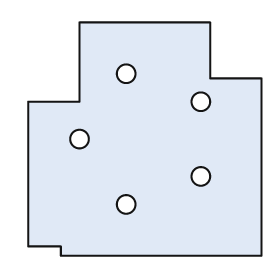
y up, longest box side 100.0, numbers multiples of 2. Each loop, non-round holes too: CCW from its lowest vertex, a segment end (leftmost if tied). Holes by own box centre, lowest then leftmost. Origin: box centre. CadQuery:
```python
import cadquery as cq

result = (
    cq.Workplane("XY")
    .moveTo(-36.0, -50.0)
    .lineTo(50.0, -50.0)
    .lineTo(50.0, 26.0)
    .lineTo(28.0, 26.0)
    .lineTo(28.0, 50.0)
    .lineTo(-28.0, 50.0)
    .lineTo(-28.0, 16.0)
    .lineTo(-50.0, 16.0)
    .lineTo(-50.0, -46.0)
    .lineTo(-36.0, -46.0)
    .close()
    .moveTo(-8.0, -28.0)
    .circle(4.0)
    .moveTo(24.0, -16.0)
    .circle(4.0)
    .moveTo(-28.0, 0.0)
    .circle(4.0)
    .moveTo(24.0, 16.0)
    .circle(4.0)
    .moveTo(-8.0, 28.0)
    .circle(4.0)
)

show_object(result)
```